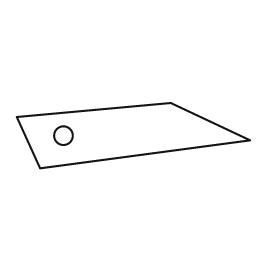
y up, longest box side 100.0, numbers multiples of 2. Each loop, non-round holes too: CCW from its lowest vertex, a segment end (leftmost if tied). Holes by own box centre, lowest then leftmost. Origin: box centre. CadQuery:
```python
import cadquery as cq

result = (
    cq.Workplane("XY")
    .moveTo(-40.0, -14.0)
    .lineTo(50.0, -2.0)
    .lineTo(16.0, 14.0)
    .lineTo(-50.0, 8.0)
    .close()
    .moveTo(-30.0, 0.0)
    .circle(4.0)
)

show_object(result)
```